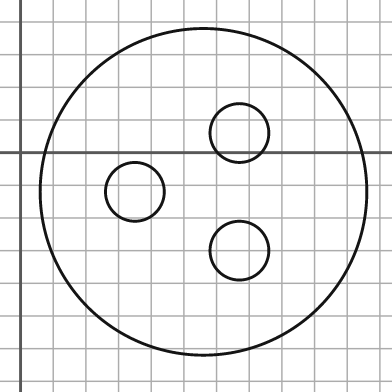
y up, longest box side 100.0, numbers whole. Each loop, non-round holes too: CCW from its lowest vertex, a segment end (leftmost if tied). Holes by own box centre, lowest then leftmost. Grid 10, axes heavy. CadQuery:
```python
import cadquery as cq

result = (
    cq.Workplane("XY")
    .moveTo(56.0, -12.0)
    .circle(50.0)
    .moveTo(67.0, -30.0)
    .circle(9.0)
    .moveTo(35.0, -12.0)
    .circle(9.0)
    .moveTo(67.0, 6.0)
    .circle(9.0)
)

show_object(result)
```